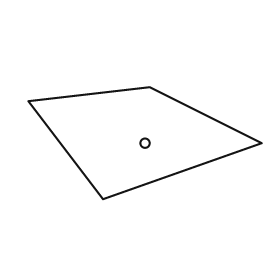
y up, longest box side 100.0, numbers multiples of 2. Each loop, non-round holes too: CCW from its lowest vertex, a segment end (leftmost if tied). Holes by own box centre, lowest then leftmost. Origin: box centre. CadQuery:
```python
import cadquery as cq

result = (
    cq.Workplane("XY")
    .moveTo(-18.0, -24.0)
    .lineTo(50.0, 0.0)
    .lineTo(2.0, 24.0)
    .lineTo(-50.0, 18.0)
    .close()
    .moveTo(0.0, 0.0)
    .circle(2.0)
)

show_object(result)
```